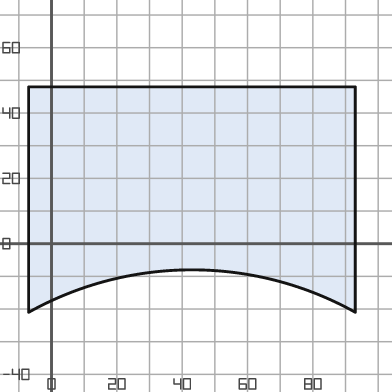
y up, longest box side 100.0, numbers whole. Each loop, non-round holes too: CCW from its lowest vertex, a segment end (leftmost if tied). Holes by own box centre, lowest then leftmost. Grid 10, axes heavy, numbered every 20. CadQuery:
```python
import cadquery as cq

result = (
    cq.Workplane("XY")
    .moveTo(-7.0, -21.0)
    .threePointArc((43.0, -8.0), (93.0, -21.0))
    .lineTo(93.0, 48.0)
    .lineTo(-7.0, 48.0)
    .close()
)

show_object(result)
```